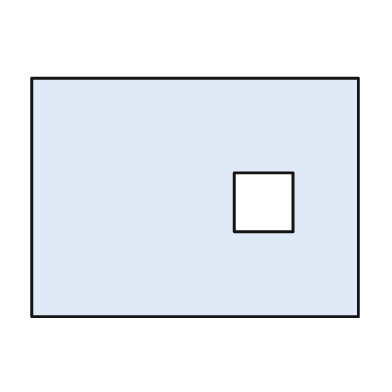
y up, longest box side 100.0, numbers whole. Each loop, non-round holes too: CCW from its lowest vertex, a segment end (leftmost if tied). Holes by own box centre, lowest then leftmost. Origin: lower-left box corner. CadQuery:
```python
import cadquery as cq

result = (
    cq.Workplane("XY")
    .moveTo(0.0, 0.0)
    .lineTo(100.0, 0.0)
    .lineTo(100.0, 73.0)
    .lineTo(0.0, 73.0)
    .close()
    .moveTo(62.0, 26.0)
    .lineTo(80.0, 26.0)
    .lineTo(80.0, 44.0)
    .lineTo(62.0, 44.0)
    .close()
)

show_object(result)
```